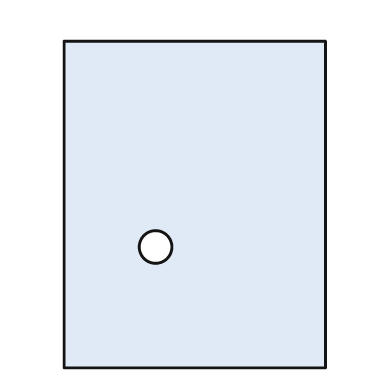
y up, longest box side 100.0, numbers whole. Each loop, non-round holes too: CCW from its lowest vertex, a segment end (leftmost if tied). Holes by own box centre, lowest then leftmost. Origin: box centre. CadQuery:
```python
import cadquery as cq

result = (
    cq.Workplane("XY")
    .moveTo(-40.0, -50.0)
    .lineTo(40.0, -50.0)
    .lineTo(40.0, 50.0)
    .lineTo(-40.0, 50.0)
    .close()
    .moveTo(-12.0, -13.0)
    .circle(5.0)
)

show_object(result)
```